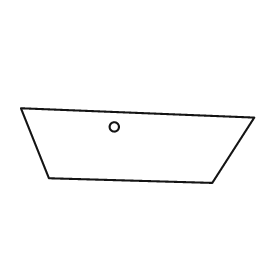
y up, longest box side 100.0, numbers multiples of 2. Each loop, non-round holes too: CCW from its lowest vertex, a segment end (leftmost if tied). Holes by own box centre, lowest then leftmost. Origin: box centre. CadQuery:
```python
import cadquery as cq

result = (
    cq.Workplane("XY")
    .moveTo(32.0, -16.0)
    .lineTo(50.0, 12.0)
    .lineTo(-50.0, 16.0)
    .lineTo(-38.0, -14.0)
    .close()
    .moveTo(-10.0, 8.0)
    .circle(2.0)
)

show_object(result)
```